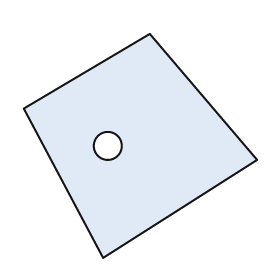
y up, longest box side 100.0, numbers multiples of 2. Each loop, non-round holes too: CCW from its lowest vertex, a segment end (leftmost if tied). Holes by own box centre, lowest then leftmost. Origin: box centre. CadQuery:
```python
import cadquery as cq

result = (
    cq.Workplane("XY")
    .moveTo(-16.0, -48.0)
    .lineTo(50.0, -6.0)
    .lineTo(4.0, 48.0)
    .lineTo(-50.0, 16.0)
    .close()
    .moveTo(-14.0, 0.0)
    .circle(6.0)
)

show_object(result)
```